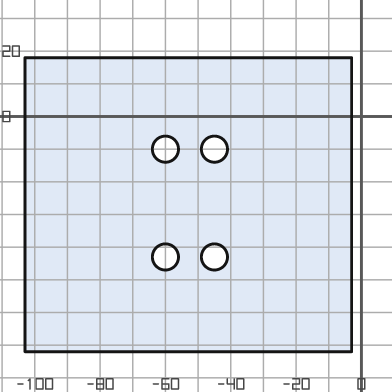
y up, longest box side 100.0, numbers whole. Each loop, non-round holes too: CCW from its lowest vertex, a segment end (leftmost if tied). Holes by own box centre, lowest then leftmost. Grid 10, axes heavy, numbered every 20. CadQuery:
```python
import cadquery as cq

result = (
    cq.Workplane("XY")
    .moveTo(-103.0, -72.0)
    .lineTo(-3.0, -72.0)
    .lineTo(-3.0, 18.0)
    .lineTo(-103.0, 18.0)
    .close()
    .moveTo(-60.0, -43.0)
    .circle(4.0)
    .moveTo(-45.0, -43.0)
    .circle(4.0)
    .moveTo(-60.0, -10.0)
    .circle(4.0)
    .moveTo(-45.0, -10.0)
    .circle(4.0)
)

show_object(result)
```